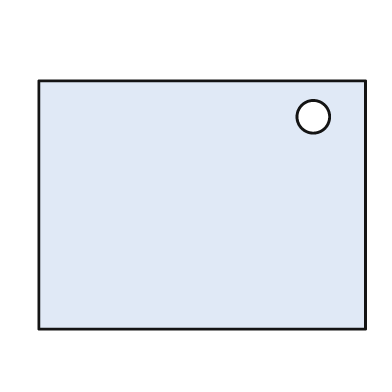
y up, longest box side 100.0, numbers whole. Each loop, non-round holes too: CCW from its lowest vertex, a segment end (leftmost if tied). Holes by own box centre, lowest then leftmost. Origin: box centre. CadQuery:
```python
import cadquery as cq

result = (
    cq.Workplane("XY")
    .moveTo(-50.0, -38.0)
    .lineTo(50.0, -38.0)
    .lineTo(50.0, 38.0)
    .lineTo(-50.0, 38.0)
    .close()
    .moveTo(34.0, 27.0)
    .circle(5.0)
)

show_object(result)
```